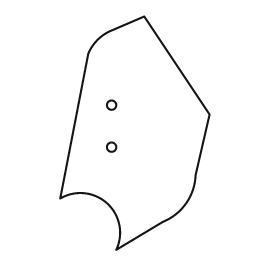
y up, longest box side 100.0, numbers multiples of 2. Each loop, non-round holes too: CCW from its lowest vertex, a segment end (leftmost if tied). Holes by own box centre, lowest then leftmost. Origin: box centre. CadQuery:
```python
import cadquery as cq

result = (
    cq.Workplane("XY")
    .moveTo(-8.0, -50.0)
    .lineTo(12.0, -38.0)
    .threePointArc((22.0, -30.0), (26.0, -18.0))
    .lineTo(32.0, 8.0)
    .lineTo(4.0, 50.0)
    .lineTo(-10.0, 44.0)
    .threePointArc((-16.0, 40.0), (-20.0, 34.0))
    .lineTo(-32.0, -28.0)
    .threePointArc((-12.0, -30.0), (-8.0, -50.0))
    .close()
    .moveTo(-10.0, -6.0)
    .circle(2.0)
    .moveTo(-10.0, 12.0)
    .circle(2.0)
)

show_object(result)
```